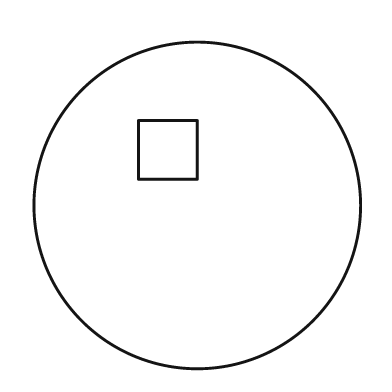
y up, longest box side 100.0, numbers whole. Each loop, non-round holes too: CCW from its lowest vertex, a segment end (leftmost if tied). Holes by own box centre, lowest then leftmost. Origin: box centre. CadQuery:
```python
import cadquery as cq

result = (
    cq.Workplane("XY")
    .moveTo(0.0, 0.0)
    .circle(50.0)
    .moveTo(-18.0, 8.0)
    .lineTo(0.0, 8.0)
    .lineTo(0.0, 26.0)
    .lineTo(-18.0, 26.0)
    .close()
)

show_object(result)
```